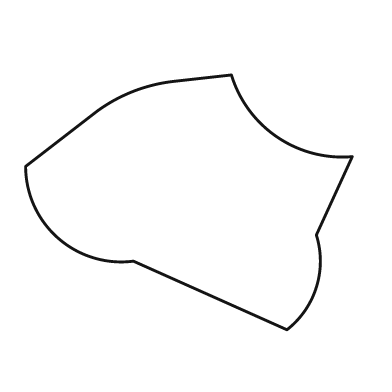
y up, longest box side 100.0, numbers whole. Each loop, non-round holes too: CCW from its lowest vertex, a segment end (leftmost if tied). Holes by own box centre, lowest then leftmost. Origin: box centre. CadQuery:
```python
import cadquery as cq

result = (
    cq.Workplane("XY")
    .moveTo(30.0, -39.0)
    .threePointArc((39.0, -26.0), (39.0, -10.0))
    .lineTo(50.0, 14.0)
    .threePointArc((27.0, 20.0), (13.0, 39.0))
    .lineTo(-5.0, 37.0)
    .threePointArc((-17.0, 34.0), (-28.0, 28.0))
    .lineTo(-50.0, 11.0)
    .threePointArc((-40.0, -11.0), (-17.0, -18.0))
    .close()
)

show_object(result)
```